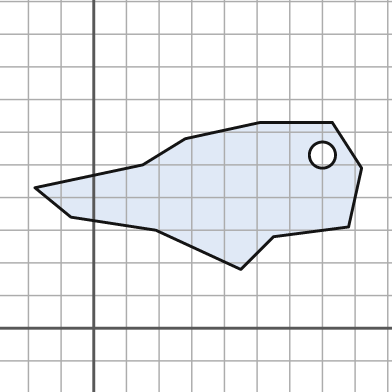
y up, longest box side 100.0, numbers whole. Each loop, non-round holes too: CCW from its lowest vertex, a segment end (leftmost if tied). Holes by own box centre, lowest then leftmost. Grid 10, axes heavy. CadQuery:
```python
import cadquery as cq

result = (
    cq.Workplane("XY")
    .moveTo(45.0, 18.0)
    .lineTo(55.0, 28.0)
    .lineTo(78.0, 31.0)
    .lineTo(82.0, 49.0)
    .lineTo(73.0, 63.0)
    .lineTo(51.0, 63.0)
    .lineTo(28.0, 58.0)
    .lineTo(15.0, 50.0)
    .lineTo(-18.0, 43.0)
    .lineTo(-7.0, 34.0)
    .lineTo(19.0, 30.0)
    .close()
    .moveTo(70.0, 53.0)
    .circle(4.0)
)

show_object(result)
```